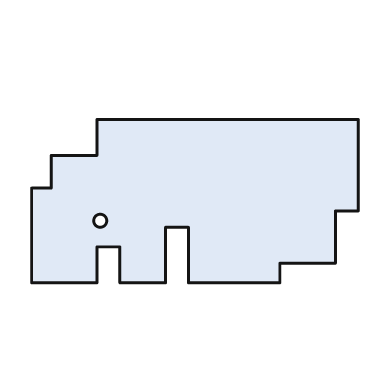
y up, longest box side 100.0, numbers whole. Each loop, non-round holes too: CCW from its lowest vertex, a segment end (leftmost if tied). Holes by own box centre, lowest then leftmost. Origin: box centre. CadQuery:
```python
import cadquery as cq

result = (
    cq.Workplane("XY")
    .moveTo(-50.0, -25.0)
    .lineTo(-30.0, -25.0)
    .lineTo(-30.0, -14.0)
    .lineTo(-23.0, -14.0)
    .lineTo(-23.0, -25.0)
    .lineTo(-9.0, -25.0)
    .lineTo(-9.0, -8.0)
    .lineTo(-2.0, -8.0)
    .lineTo(-2.0, -25.0)
    .lineTo(26.0, -25.0)
    .lineTo(26.0, -19.0)
    .lineTo(43.0, -19.0)
    .lineTo(43.0, -3.0)
    .lineTo(50.0, -3.0)
    .lineTo(50.0, 25.0)
    .lineTo(-30.0, 25.0)
    .lineTo(-30.0, 14.0)
    .lineTo(-44.0, 14.0)
    .lineTo(-44.0, 4.0)
    .lineTo(-50.0, 4.0)
    .close()
    .moveTo(-29.0, -6.0)
    .circle(2.0)
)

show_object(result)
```